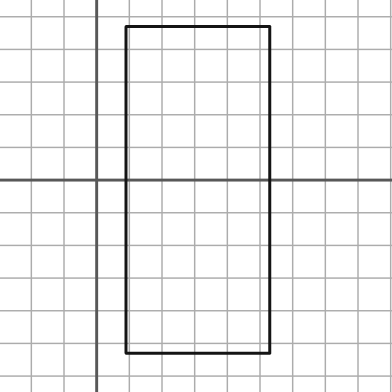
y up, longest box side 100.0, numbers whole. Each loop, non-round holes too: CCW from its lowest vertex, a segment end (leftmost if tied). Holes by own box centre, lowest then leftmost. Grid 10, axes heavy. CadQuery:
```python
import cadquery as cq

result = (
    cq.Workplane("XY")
    .moveTo(9.0, -53.0)
    .lineTo(53.0, -53.0)
    .lineTo(53.0, 47.0)
    .lineTo(9.0, 47.0)
    .close()
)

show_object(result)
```